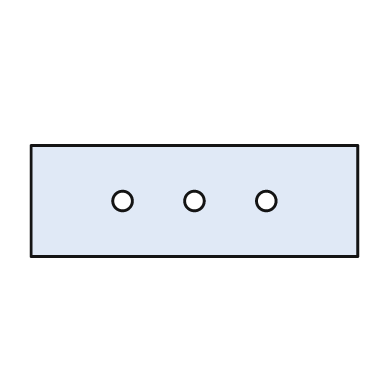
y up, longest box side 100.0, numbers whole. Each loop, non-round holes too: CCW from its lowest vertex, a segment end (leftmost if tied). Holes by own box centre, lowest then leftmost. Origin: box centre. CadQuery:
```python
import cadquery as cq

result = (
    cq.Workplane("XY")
    .moveTo(-50.0, -17.0)
    .lineTo(50.0, -17.0)
    .lineTo(50.0, 17.0)
    .lineTo(-50.0, 17.0)
    .close()
    .moveTo(-22.0, 0.0)
    .circle(3.0)
    .moveTo(0.0, 0.0)
    .circle(3.0)
    .moveTo(22.0, 0.0)
    .circle(3.0)
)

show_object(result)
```